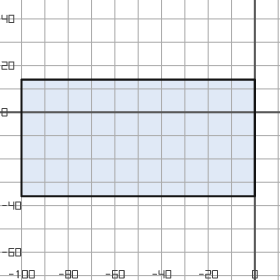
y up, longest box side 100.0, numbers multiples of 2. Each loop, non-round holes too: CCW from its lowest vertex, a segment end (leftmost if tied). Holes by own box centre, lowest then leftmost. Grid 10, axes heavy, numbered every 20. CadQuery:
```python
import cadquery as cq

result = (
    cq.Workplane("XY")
    .moveTo(-100.0, -36.0)
    .lineTo(0.0, -36.0)
    .lineTo(0.0, 14.0)
    .lineTo(-100.0, 14.0)
    .close()
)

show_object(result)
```